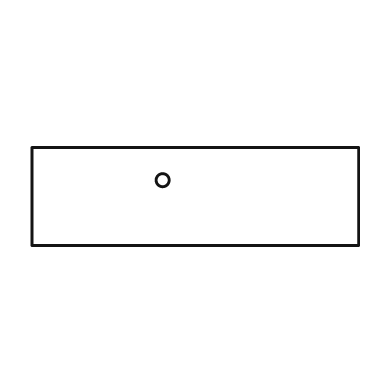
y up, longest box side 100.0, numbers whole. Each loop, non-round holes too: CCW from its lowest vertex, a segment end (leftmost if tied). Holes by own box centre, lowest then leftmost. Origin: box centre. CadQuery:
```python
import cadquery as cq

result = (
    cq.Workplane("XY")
    .moveTo(-50.0, -15.0)
    .lineTo(50.0, -15.0)
    .lineTo(50.0, 15.0)
    .lineTo(-50.0, 15.0)
    .close()
    .moveTo(-10.0, 5.0)
    .circle(2.0)
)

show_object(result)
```